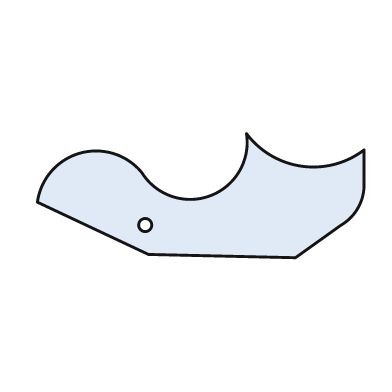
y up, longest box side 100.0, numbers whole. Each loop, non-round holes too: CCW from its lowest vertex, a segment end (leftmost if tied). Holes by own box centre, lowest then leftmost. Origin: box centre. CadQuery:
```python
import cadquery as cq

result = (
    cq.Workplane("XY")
    .moveTo(29.0, -19.0)
    .lineTo(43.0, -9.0)
    .threePointArc((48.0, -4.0), (50.0, 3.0))
    .lineTo(50.0, 14.0)
    .threePointArc((31.0, 9.0), (14.0, 19.0))
    .threePointArc((3.0, 0.0), (-18.0, 7.0))
    .threePointArc((-37.0, 13.0), (-50.0, -2.0))
    .lineTo(-16.0, -18.0)
    .close()
    .moveTo(-17.0, -9.0)
    .circle(2.0)
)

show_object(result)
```